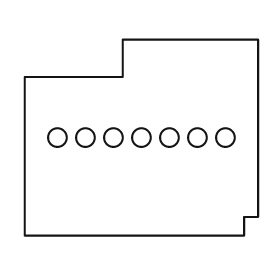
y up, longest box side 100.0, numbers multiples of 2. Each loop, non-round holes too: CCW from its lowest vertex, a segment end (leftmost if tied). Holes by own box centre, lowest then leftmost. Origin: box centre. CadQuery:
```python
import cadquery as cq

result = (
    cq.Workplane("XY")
    .moveTo(-50.0, -42.0)
    .lineTo(44.0, -42.0)
    .lineTo(44.0, -34.0)
    .lineTo(50.0, -34.0)
    .lineTo(50.0, 42.0)
    .lineTo(-8.0, 42.0)
    .lineTo(-8.0, 26.0)
    .lineTo(-50.0, 26.0)
    .close()
    .moveTo(-36.0, 0.0)
    .circle(4.0)
    .moveTo(-24.0, 0.0)
    .circle(4.0)
    .moveTo(-12.0, 0.0)
    .circle(4.0)
    .moveTo(0.0, 0.0)
    .circle(4.0)
    .moveTo(12.0, 0.0)
    .circle(4.0)
    .moveTo(24.0, 0.0)
    .circle(4.0)
    .moveTo(36.0, 0.0)
    .circle(4.0)
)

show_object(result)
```